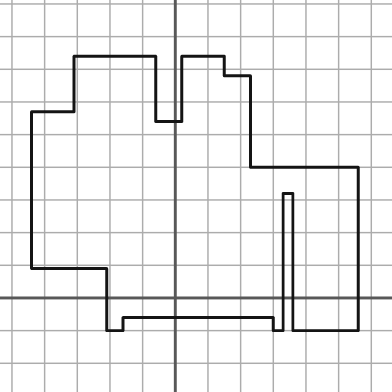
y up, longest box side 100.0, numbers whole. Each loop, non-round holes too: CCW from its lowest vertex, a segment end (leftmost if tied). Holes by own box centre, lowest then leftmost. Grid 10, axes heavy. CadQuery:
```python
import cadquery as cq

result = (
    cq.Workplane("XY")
    .moveTo(-21.0, -10.0)
    .lineTo(-16.0, -10.0)
    .lineTo(-16.0, -6.0)
    .lineTo(30.0, -6.0)
    .lineTo(30.0, -10.0)
    .lineTo(33.0, -10.0)
    .lineTo(33.0, 32.0)
    .lineTo(36.0, 32.0)
    .lineTo(36.0, -10.0)
    .lineTo(56.0, -10.0)
    .lineTo(56.0, 40.0)
    .lineTo(23.0, 40.0)
    .lineTo(23.0, 68.0)
    .lineTo(15.0, 68.0)
    .lineTo(15.0, 74.0)
    .lineTo(2.0, 74.0)
    .lineTo(2.0, 54.0)
    .lineTo(-6.0, 54.0)
    .lineTo(-6.0, 74.0)
    .lineTo(-31.0, 74.0)
    .lineTo(-31.0, 57.0)
    .lineTo(-44.0, 57.0)
    .lineTo(-44.0, 9.0)
    .lineTo(-21.0, 9.0)
    .close()
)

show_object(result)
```